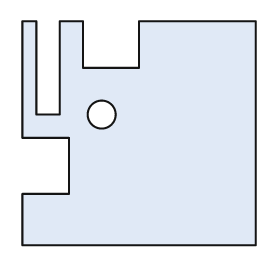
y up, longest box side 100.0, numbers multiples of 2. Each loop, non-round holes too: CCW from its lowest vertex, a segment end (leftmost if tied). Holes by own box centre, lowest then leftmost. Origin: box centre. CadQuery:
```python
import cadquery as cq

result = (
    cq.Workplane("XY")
    .moveTo(-50.0, -48.0)
    .lineTo(50.0, -48.0)
    .lineTo(50.0, 48.0)
    .lineTo(0.0, 48.0)
    .lineTo(0.0, 28.0)
    .lineTo(-24.0, 28.0)
    .lineTo(-24.0, 48.0)
    .lineTo(-34.0, 48.0)
    .lineTo(-34.0, 8.0)
    .lineTo(-44.0, 8.0)
    .lineTo(-44.0, 48.0)
    .lineTo(-50.0, 48.0)
    .lineTo(-50.0, -2.0)
    .lineTo(-30.0, -2.0)
    .lineTo(-30.0, -26.0)
    .lineTo(-50.0, -26.0)
    .close()
    .moveTo(-16.0, 8.0)
    .circle(6.0)
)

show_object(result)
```